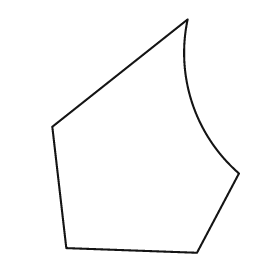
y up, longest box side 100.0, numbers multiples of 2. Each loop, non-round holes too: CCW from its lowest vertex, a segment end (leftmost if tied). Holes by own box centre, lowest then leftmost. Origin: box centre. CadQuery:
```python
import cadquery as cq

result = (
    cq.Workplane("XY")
    .moveTo(22.0, -50.0)
    .lineTo(40.0, -16.0)
    .threePointArc((20.0, 14.0), (18.0, 50.0))
    .lineTo(-40.0, 4.0)
    .lineTo(-34.0, -48.0)
    .close()
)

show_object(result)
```